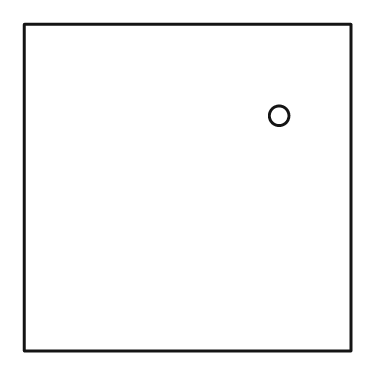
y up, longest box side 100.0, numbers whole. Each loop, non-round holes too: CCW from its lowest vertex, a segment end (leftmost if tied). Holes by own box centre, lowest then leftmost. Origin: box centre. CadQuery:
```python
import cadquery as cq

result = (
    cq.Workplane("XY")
    .moveTo(-50.0, -50.0)
    .lineTo(50.0, -50.0)
    .lineTo(50.0, 50.0)
    .lineTo(-50.0, 50.0)
    .close()
    .moveTo(28.0, 22.0)
    .circle(3.0)
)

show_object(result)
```